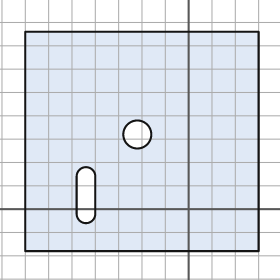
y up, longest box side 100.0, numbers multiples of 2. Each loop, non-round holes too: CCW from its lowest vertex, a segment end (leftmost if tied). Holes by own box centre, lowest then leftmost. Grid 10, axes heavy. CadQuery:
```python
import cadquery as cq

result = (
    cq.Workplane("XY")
    .moveTo(-70.0, -18.0)
    .lineTo(30.0, -18.0)
    .lineTo(30.0, 76.0)
    .lineTo(-70.0, 76.0)
    .close()
    .moveTo(-48.0, -2.0)
    .threePointArc((-44.0, -6.0), (-40.0, -2.0))
    .lineTo(-40.0, 14.0)
    .threePointArc((-44.0, 18.0), (-48.0, 14.0))
    .close()
    .moveTo(-22.0, 32.0)
    .circle(6.0)
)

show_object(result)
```